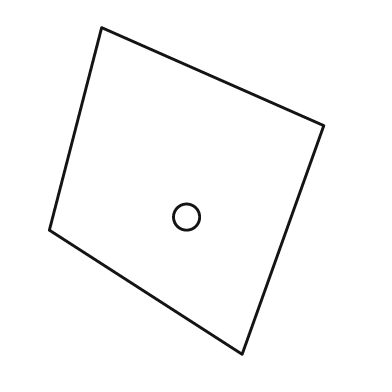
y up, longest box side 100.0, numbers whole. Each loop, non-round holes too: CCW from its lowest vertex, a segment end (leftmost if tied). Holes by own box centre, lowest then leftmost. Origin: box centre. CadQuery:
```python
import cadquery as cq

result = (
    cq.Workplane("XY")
    .moveTo(17.0, -50.0)
    .lineTo(42.0, 20.0)
    .lineTo(-26.0, 50.0)
    .lineTo(-42.0, -12.0)
    .close()
    .moveTo(0.0, -8.0)
    .circle(4.0)
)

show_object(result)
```